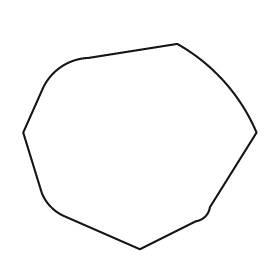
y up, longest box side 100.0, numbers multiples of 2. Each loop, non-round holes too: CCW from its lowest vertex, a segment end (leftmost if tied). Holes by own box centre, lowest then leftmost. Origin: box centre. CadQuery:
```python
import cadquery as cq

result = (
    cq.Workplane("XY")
    .moveTo(0.0, -44.0)
    .lineTo(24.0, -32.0)
    .threePointArc((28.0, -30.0), (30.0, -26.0))
    .lineTo(50.0, 6.0)
    .threePointArc((36.0, 28.0), (16.0, 44.0))
    .lineTo(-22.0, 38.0)
    .threePointArc((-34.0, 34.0), (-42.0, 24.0))
    .lineTo(-50.0, 6.0)
    .lineTo(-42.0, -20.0)
    .threePointArc((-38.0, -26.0), (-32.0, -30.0))
    .close()
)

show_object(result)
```